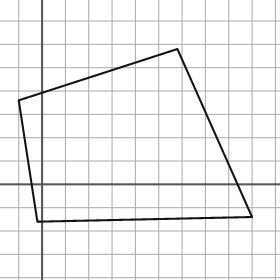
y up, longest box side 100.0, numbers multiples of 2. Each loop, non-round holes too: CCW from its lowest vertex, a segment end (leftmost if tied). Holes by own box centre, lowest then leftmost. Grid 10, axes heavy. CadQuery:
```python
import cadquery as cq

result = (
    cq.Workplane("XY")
    .moveTo(-2.0, -16.0)
    .lineTo(90.0, -14.0)
    .lineTo(58.0, 58.0)
    .lineTo(-10.0, 36.0)
    .close()
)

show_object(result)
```